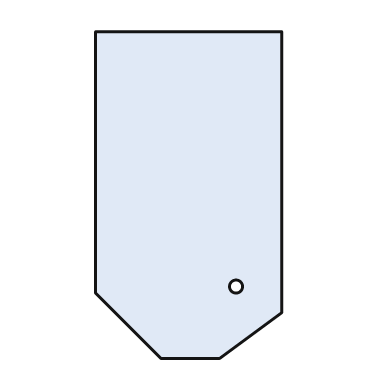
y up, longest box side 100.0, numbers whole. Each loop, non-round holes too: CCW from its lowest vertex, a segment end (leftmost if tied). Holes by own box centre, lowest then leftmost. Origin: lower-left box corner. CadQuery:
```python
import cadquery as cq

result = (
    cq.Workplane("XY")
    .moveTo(20.0, 0.0)
    .lineTo(38.0, 0.0)
    .lineTo(57.0, 14.0)
    .lineTo(57.0, 100.0)
    .lineTo(0.0, 100.0)
    .lineTo(0.0, 20.0)
    .close()
    .moveTo(43.0, 22.0)
    .circle(2.0)
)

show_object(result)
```